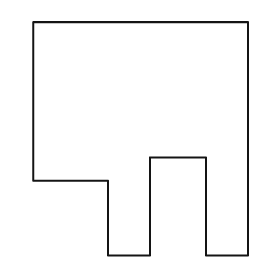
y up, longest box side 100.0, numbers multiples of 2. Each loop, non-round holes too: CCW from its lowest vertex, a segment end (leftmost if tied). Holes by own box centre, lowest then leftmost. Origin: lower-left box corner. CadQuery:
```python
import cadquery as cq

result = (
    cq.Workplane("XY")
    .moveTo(32.0, 0.0)
    .lineTo(50.0, 0.0)
    .lineTo(50.0, 42.0)
    .lineTo(74.0, 42.0)
    .lineTo(74.0, 0.0)
    .lineTo(92.0, 0.0)
    .lineTo(92.0, 100.0)
    .lineTo(0.0, 100.0)
    .lineTo(0.0, 32.0)
    .lineTo(32.0, 32.0)
    .close()
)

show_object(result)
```